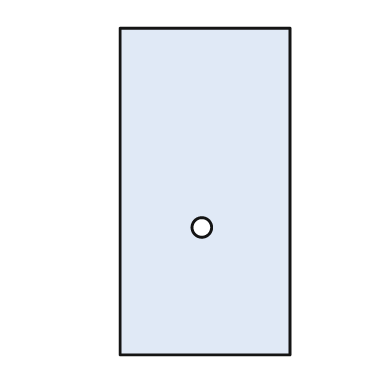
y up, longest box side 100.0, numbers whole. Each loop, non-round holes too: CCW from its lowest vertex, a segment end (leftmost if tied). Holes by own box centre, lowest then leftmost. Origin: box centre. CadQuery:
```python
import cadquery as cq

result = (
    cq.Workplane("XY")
    .moveTo(-26.0, -50.0)
    .lineTo(26.0, -50.0)
    .lineTo(26.0, 50.0)
    .lineTo(-26.0, 50.0)
    .close()
    .moveTo(-1.0, -11.0)
    .circle(3.0)
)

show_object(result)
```